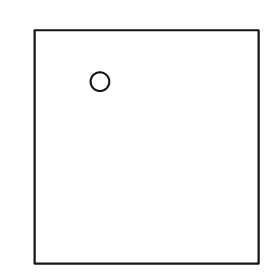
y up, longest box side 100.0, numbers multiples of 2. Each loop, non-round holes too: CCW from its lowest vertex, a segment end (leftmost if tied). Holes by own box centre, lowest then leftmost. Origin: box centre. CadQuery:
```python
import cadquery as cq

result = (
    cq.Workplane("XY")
    .moveTo(-48.0, -50.0)
    .lineTo(48.0, -50.0)
    .lineTo(48.0, 50.0)
    .lineTo(-48.0, 50.0)
    .close()
    .moveTo(-20.0, 28.0)
    .circle(4.0)
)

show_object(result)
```